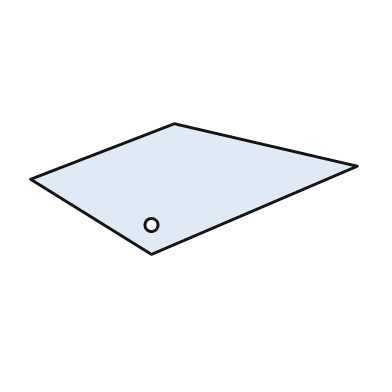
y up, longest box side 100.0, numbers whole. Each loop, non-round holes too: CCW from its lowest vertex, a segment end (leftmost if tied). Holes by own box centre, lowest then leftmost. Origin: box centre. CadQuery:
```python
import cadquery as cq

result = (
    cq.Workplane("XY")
    .moveTo(-13.0, -20.0)
    .lineTo(50.0, 7.0)
    .lineTo(-6.0, 20.0)
    .lineTo(-50.0, 3.0)
    .close()
    .moveTo(-13.0, -11.0)
    .circle(2.0)
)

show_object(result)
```